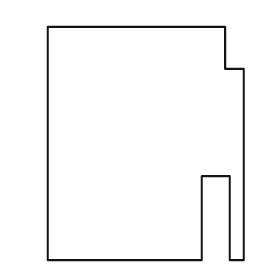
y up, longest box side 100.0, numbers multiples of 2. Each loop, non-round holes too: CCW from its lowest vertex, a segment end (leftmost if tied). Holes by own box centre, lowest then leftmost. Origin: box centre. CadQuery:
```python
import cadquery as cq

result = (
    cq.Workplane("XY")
    .moveTo(-42.0, -50.0)
    .lineTo(24.0, -50.0)
    .lineTo(24.0, -14.0)
    .lineTo(36.0, -14.0)
    .lineTo(36.0, -50.0)
    .lineTo(42.0, -50.0)
    .lineTo(42.0, 32.0)
    .lineTo(34.0, 32.0)
    .lineTo(34.0, 50.0)
    .lineTo(-42.0, 50.0)
    .close()
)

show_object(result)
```